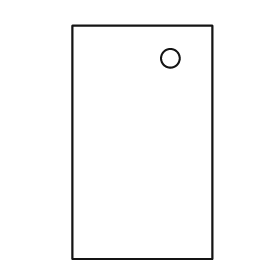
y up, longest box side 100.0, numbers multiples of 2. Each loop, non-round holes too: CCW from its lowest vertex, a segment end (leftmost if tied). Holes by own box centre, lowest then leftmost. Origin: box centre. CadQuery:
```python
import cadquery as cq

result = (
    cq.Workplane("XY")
    .moveTo(-30.0, -50.0)
    .lineTo(30.0, -50.0)
    .lineTo(30.0, 50.0)
    .lineTo(-30.0, 50.0)
    .close()
    .moveTo(12.0, 36.0)
    .circle(4.0)
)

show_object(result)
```